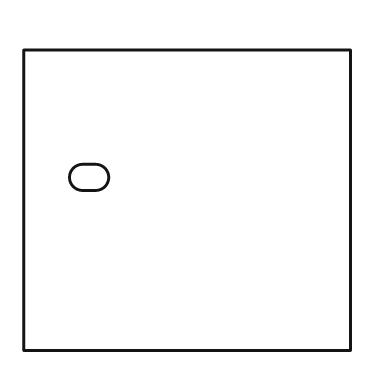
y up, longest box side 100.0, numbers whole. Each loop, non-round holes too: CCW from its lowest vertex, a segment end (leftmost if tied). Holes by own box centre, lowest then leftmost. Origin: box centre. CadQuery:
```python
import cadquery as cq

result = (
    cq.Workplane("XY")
    .moveTo(-50.0, -46.0)
    .lineTo(50.0, -46.0)
    .lineTo(50.0, 46.0)
    .lineTo(-50.0, 46.0)
    .close()
    .moveTo(-32.0, 3.0)
    .lineTo(-28.0, 3.0)
    .threePointArc((-24.0, 7.0), (-28.0, 11.0))
    .lineTo(-32.0, 11.0)
    .threePointArc((-36.0, 7.0), (-32.0, 3.0))
    .close()
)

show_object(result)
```